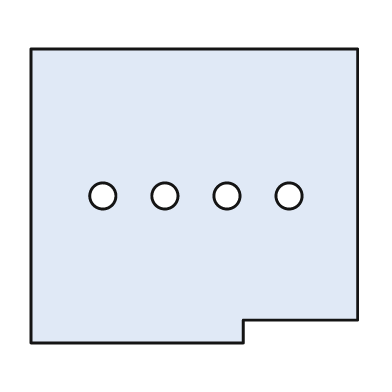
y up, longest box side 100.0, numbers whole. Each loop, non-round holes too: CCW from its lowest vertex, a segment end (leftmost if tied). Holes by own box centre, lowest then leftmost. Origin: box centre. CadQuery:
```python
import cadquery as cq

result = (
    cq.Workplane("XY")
    .moveTo(-50.0, -45.0)
    .lineTo(15.0, -45.0)
    .lineTo(15.0, -38.0)
    .lineTo(50.0, -38.0)
    .lineTo(50.0, 45.0)
    .lineTo(-50.0, 45.0)
    .close()
    .moveTo(-28.0, 0.0)
    .circle(4.0)
    .moveTo(-9.0, 0.0)
    .circle(4.0)
    .moveTo(10.0, 0.0)
    .circle(4.0)
    .moveTo(29.0, 0.0)
    .circle(4.0)
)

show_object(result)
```